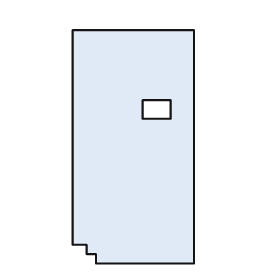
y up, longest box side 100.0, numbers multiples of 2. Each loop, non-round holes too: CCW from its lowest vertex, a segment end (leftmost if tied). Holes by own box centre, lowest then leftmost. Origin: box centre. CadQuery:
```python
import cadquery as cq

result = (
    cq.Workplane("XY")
    .moveTo(-16.0, -50.0)
    .lineTo(26.0, -50.0)
    .lineTo(26.0, 50.0)
    .lineTo(-26.0, 50.0)
    .lineTo(-26.0, -42.0)
    .lineTo(-20.0, -42.0)
    .lineTo(-20.0, -46.0)
    .lineTo(-16.0, -46.0)
    .close()
    .moveTo(4.0, 12.0)
    .lineTo(16.0, 12.0)
    .lineTo(16.0, 20.0)
    .lineTo(4.0, 20.0)
    .close()
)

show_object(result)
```